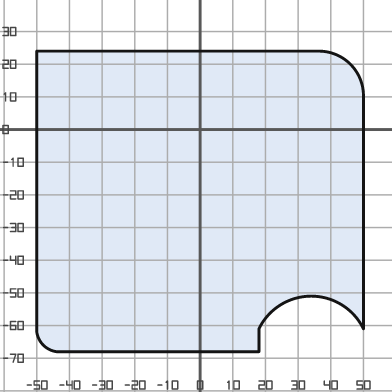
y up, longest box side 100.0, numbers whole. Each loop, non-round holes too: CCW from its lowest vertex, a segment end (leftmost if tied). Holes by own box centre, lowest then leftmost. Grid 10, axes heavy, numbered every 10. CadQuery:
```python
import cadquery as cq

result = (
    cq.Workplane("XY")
    .moveTo(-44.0, -68.0)
    .lineTo(18.0, -68.0)
    .lineTo(18.0, -61.0)
    .threePointArc((34.0, -51.0), (50.0, -61.0))
    .lineTo(50.0, 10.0)
    .threePointArc((46.0, 20.0), (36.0, 24.0))
    .lineTo(-50.0, 24.0)
    .lineTo(-50.0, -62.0)
    .threePointArc((-48.0, -66.0), (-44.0, -68.0))
    .close()
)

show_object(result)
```